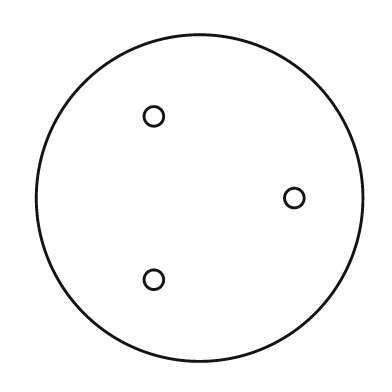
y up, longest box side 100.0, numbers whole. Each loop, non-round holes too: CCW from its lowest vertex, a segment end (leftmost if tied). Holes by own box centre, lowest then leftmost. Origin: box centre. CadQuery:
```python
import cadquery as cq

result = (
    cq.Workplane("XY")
    .moveTo(0.0, 0.0)
    .circle(50.0)
    .moveTo(-14.0, -25.0)
    .circle(3.0)
    .moveTo(29.0, 0.0)
    .circle(3.0)
    .moveTo(-14.0, 25.0)
    .circle(3.0)
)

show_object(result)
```